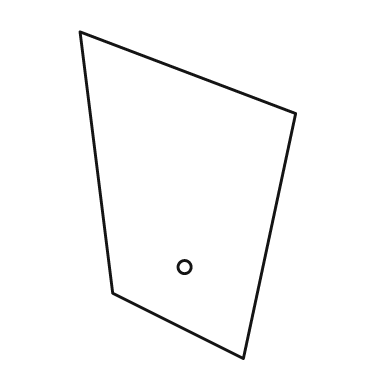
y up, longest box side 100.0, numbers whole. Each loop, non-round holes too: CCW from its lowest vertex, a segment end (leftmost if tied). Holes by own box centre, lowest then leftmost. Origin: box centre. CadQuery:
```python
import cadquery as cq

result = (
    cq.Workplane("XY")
    .moveTo(17.0, -50.0)
    .lineTo(33.0, 25.0)
    .lineTo(-33.0, 50.0)
    .lineTo(-23.0, -30.0)
    .close()
    .moveTo(-1.0, -22.0)
    .circle(2.0)
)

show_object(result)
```